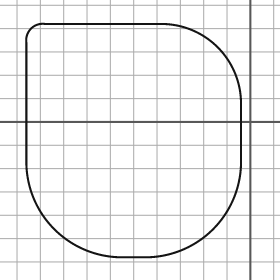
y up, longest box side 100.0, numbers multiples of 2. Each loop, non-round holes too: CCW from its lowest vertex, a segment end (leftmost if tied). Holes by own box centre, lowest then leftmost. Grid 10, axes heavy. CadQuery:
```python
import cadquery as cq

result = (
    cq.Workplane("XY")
    .moveTo(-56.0, -58.0)
    .lineTo(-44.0, -58.0)
    .threePointArc((-16.0, -46.0), (-4.0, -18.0))
    .lineTo(-4.0, 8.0)
    .threePointArc((-14.0, 32.0), (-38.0, 42.0))
    .lineTo(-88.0, 42.0)
    .threePointArc((-94.0, 40.0), (-96.0, 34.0))
    .lineTo(-96.0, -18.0)
    .threePointArc((-84.0, -46.0), (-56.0, -58.0))
    .close()
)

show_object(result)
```